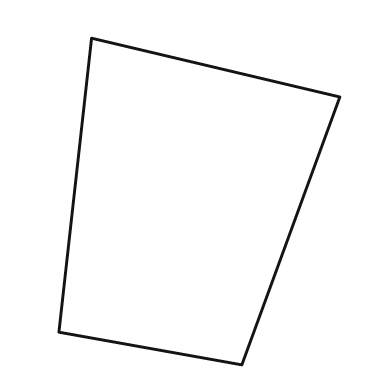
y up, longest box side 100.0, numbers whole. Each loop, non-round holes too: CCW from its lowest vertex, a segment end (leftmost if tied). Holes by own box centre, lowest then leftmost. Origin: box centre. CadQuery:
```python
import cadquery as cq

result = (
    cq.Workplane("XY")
    .moveTo(13.0, -50.0)
    .lineTo(43.0, 32.0)
    .lineTo(-33.0, 50.0)
    .lineTo(-43.0, -40.0)
    .close()
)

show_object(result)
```